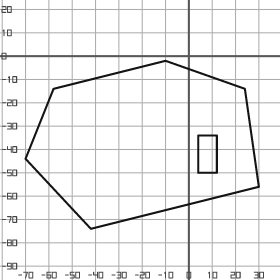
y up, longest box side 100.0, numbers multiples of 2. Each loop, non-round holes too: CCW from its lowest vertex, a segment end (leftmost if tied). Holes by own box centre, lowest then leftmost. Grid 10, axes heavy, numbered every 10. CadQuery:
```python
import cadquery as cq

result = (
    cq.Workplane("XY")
    .moveTo(-42.0, -74.0)
    .lineTo(30.0, -56.0)
    .lineTo(24.0, -14.0)
    .lineTo(-10.0, -2.0)
    .lineTo(-58.0, -14.0)
    .lineTo(-70.0, -44.0)
    .close()
    .moveTo(4.0, -50.0)
    .lineTo(12.0, -50.0)
    .lineTo(12.0, -34.0)
    .lineTo(4.0, -34.0)
    .close()
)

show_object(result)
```